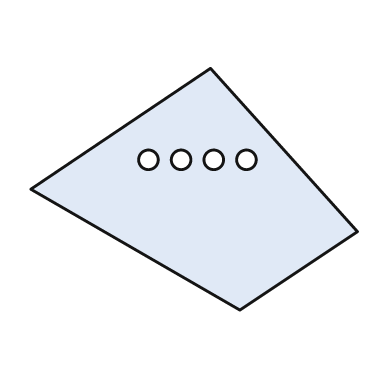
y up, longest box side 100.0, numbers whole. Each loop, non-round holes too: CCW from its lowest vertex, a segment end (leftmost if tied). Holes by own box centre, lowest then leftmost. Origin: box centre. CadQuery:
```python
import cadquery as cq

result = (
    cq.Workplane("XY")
    .moveTo(14.0, -37.0)
    .lineTo(50.0, -13.0)
    .lineTo(5.0, 37.0)
    .lineTo(-50.0, 0.0)
    .close()
    .moveTo(-14.0, 9.0)
    .circle(3.0)
    .moveTo(-4.0, 9.0)
    .circle(3.0)
    .moveTo(6.0, 9.0)
    .circle(3.0)
    .moveTo(16.0, 9.0)
    .circle(3.0)
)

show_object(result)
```